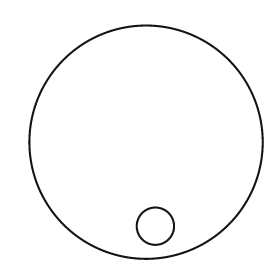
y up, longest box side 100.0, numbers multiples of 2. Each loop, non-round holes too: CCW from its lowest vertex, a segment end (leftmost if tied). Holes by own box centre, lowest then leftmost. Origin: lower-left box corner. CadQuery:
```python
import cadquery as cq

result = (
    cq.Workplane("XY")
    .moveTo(50.0, 50.0)
    .circle(50.0)
    .moveTo(54.0, 14.0)
    .circle(8.0)
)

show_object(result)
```